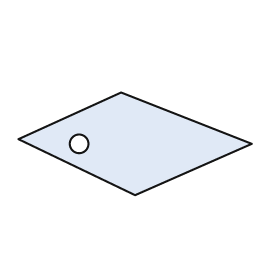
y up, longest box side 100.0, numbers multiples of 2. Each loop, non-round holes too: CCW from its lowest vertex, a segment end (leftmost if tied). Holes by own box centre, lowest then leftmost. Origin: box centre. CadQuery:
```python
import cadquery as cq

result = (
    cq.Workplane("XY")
    .moveTo(0.0, -22.0)
    .lineTo(50.0, 0.0)
    .lineTo(-6.0, 22.0)
    .lineTo(-50.0, 2.0)
    .close()
    .moveTo(-24.0, 0.0)
    .circle(4.0)
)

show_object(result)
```